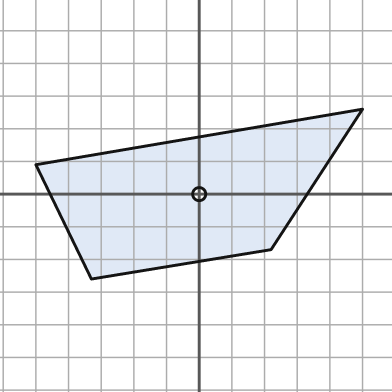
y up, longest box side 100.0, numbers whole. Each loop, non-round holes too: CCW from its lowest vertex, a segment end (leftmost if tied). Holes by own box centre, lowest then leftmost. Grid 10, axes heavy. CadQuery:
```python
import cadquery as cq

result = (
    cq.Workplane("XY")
    .moveTo(-33.0, -26.0)
    .lineTo(22.0, -17.0)
    .lineTo(50.0, 26.0)
    .lineTo(-50.0, 9.0)
    .close()
    .moveTo(0.0, 0.0)
    .circle(2.0)
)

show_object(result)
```